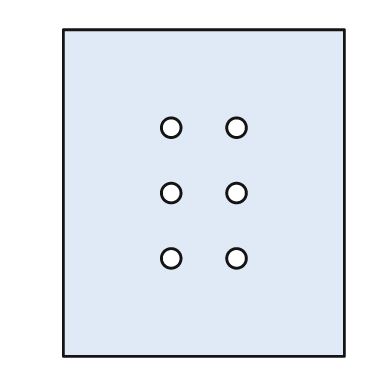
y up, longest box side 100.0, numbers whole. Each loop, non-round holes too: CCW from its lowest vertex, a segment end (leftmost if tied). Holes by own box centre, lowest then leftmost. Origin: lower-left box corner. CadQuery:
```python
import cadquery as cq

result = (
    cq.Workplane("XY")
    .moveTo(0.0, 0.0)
    .lineTo(86.0, 0.0)
    .lineTo(86.0, 100.0)
    .lineTo(0.0, 100.0)
    .close()
    .moveTo(33.0, 30.0)
    .circle(3.0)
    .moveTo(53.0, 30.0)
    .circle(3.0)
    .moveTo(33.0, 50.0)
    .circle(3.0)
    .moveTo(53.0, 50.0)
    .circle(3.0)
    .moveTo(33.0, 70.0)
    .circle(3.0)
    .moveTo(53.0, 70.0)
    .circle(3.0)
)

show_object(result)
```